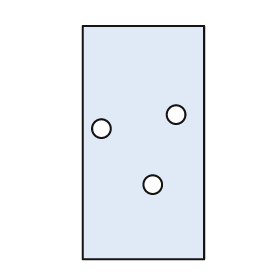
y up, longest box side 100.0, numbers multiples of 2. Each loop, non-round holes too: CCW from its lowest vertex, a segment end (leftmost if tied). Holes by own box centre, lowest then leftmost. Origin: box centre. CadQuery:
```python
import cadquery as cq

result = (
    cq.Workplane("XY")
    .moveTo(-26.0, -50.0)
    .lineTo(26.0, -50.0)
    .lineTo(26.0, 50.0)
    .lineTo(-26.0, 50.0)
    .close()
    .moveTo(4.0, -18.0)
    .circle(4.0)
    .moveTo(-18.0, 6.0)
    .circle(4.0)
    .moveTo(14.0, 12.0)
    .circle(4.0)
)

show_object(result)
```